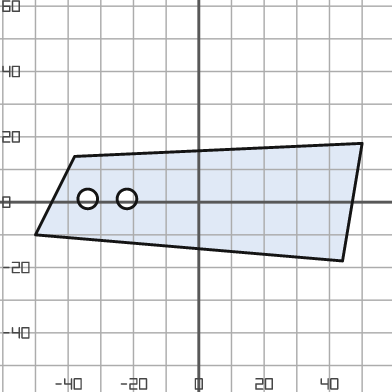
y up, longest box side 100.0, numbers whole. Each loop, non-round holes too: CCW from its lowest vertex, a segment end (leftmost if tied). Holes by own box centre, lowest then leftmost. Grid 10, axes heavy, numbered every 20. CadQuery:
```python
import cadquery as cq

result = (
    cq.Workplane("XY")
    .moveTo(44.0, -18.0)
    .lineTo(50.0, 18.0)
    .lineTo(-38.0, 14.0)
    .lineTo(-50.0, -10.0)
    .close()
    .moveTo(-34.0, 1.0)
    .circle(3.0)
    .moveTo(-22.0, 1.0)
    .circle(3.0)
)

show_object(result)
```